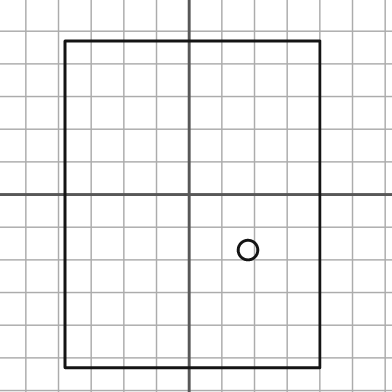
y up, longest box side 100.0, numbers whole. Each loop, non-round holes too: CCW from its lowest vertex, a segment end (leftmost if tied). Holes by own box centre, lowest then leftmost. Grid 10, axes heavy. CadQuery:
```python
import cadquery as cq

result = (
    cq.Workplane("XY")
    .moveTo(-38.0, -53.0)
    .lineTo(40.0, -53.0)
    .lineTo(40.0, 47.0)
    .lineTo(-38.0, 47.0)
    .close()
    .moveTo(18.0, -17.0)
    .circle(3.0)
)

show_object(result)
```